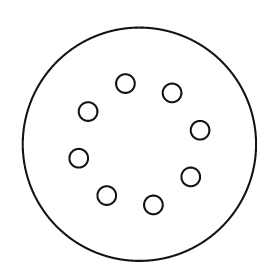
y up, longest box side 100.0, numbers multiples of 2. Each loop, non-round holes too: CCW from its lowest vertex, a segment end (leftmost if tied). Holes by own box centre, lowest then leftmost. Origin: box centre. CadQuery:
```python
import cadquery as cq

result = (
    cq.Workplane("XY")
    .moveTo(0.0, 0.0)
    .circle(50.0)
    .moveTo(6.0, -26.0)
    .circle(4.0)
    .moveTo(-14.0, -22.0)
    .circle(4.0)
    .moveTo(22.0, -14.0)
    .circle(4.0)
    .moveTo(-26.0, -6.0)
    .circle(4.0)
    .moveTo(26.0, 6.0)
    .circle(4.0)
    .moveTo(-22.0, 14.0)
    .circle(4.0)
    .moveTo(14.0, 22.0)
    .circle(4.0)
    .moveTo(-6.0, 26.0)
    .circle(4.0)
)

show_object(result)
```